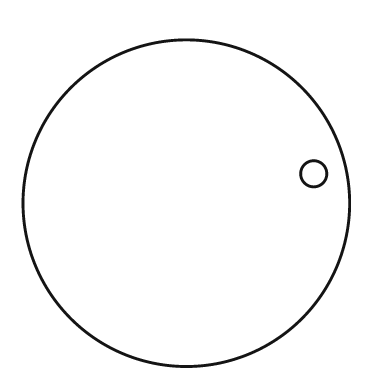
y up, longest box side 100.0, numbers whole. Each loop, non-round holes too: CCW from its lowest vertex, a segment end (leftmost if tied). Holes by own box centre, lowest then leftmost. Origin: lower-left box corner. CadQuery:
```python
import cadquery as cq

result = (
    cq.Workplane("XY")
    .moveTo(50.0, 50.0)
    .circle(50.0)
    .moveTo(89.0, 59.0)
    .circle(4.0)
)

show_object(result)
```